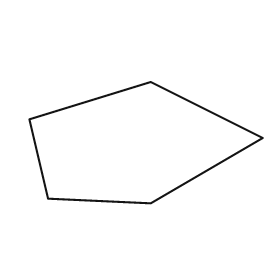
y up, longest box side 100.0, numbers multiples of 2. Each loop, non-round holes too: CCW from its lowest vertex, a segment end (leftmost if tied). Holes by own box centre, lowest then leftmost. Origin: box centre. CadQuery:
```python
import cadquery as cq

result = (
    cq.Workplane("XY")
    .moveTo(2.0, -26.0)
    .lineTo(50.0, 2.0)
    .lineTo(2.0, 26.0)
    .lineTo(-50.0, 10.0)
    .lineTo(-42.0, -24.0)
    .close()
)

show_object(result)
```